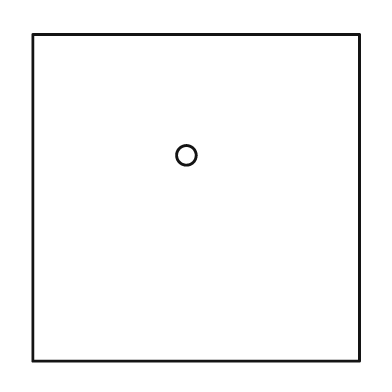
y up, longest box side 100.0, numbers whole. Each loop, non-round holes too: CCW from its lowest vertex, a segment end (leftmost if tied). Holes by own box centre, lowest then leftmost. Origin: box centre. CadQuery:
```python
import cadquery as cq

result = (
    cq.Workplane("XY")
    .moveTo(-50.0, -50.0)
    .lineTo(50.0, -50.0)
    .lineTo(50.0, 50.0)
    .lineTo(-50.0, 50.0)
    .close()
    .moveTo(-3.0, 13.0)
    .circle(3.0)
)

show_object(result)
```